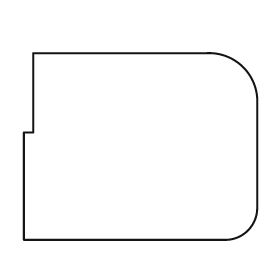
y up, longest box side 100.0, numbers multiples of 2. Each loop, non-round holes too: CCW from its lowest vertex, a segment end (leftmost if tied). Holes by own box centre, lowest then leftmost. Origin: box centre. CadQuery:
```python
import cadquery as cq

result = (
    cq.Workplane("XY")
    .moveTo(-50.0, -40.0)
    .lineTo(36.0, -40.0)
    .threePointArc((46.0, -36.0), (50.0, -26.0))
    .lineTo(50.0, 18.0)
    .threePointArc((44.0, 34.0), (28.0, 40.0))
    .lineTo(-46.0, 40.0)
    .lineTo(-46.0, 6.0)
    .lineTo(-50.0, 6.0)
    .close()
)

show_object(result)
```